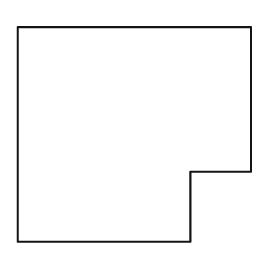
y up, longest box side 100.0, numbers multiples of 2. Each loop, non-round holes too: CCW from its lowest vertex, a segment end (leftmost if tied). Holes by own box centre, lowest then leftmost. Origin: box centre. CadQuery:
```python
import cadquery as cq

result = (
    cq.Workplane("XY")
    .moveTo(-50.0, -46.0)
    .lineTo(24.0, -46.0)
    .lineTo(24.0, -16.0)
    .lineTo(50.0, -16.0)
    .lineTo(50.0, 46.0)
    .lineTo(-50.0, 46.0)
    .close()
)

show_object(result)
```